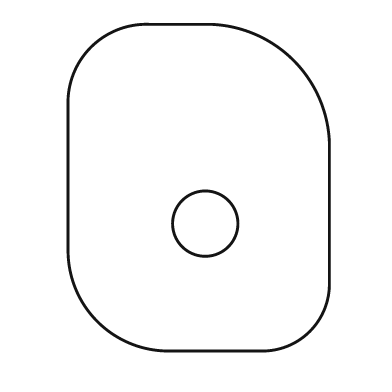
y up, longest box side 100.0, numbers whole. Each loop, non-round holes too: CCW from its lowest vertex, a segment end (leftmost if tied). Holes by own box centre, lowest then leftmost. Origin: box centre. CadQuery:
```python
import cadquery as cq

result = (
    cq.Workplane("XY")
    .moveTo(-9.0, -50.0)
    .lineTo(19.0, -50.0)
    .threePointArc((34.0, -44.0), (40.0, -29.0))
    .lineTo(40.0, 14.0)
    .threePointArc((29.0, 39.0), (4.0, 50.0))
    .lineTo(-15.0, 50.0)
    .threePointArc((-33.0, 43.0), (-40.0, 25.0))
    .lineTo(-40.0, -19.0)
    .threePointArc((-31.0, -41.0), (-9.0, -50.0))
    .close()
    .moveTo(2.0, -11.0)
    .circle(10.0)
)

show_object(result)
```